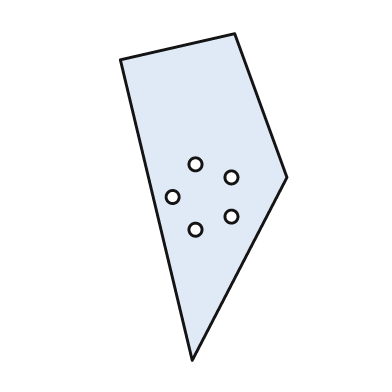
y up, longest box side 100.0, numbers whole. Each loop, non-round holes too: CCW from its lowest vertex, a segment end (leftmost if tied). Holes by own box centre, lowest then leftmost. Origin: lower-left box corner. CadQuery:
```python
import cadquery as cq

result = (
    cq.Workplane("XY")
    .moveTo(22.0, 0.0)
    .lineTo(51.0, 56.0)
    .lineTo(35.0, 100.0)
    .lineTo(0.0, 92.0)
    .close()
    .moveTo(23.0, 40.0)
    .circle(2.0)
    .moveTo(34.0, 44.0)
    .circle(2.0)
    .moveTo(16.0, 50.0)
    .circle(2.0)
    .moveTo(34.0, 56.0)
    .circle(2.0)
    .moveTo(23.0, 60.0)
    .circle(2.0)
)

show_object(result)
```